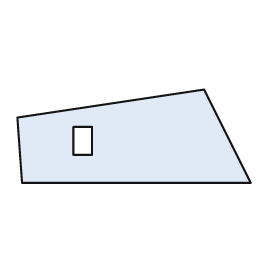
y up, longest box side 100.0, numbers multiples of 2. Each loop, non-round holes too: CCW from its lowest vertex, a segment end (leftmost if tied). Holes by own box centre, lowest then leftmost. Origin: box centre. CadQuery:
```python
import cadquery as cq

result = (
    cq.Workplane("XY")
    .moveTo(-48.0, -20.0)
    .lineTo(50.0, -20.0)
    .lineTo(30.0, 20.0)
    .lineTo(-50.0, 8.0)
    .close()
    .moveTo(-26.0, -8.0)
    .lineTo(-18.0, -8.0)
    .lineTo(-18.0, 4.0)
    .lineTo(-26.0, 4.0)
    .close()
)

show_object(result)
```